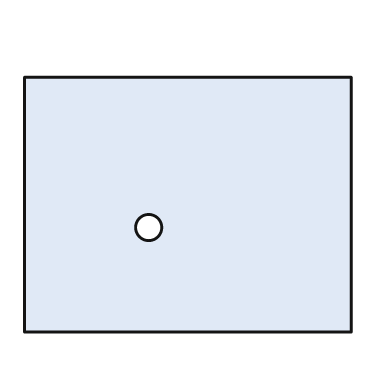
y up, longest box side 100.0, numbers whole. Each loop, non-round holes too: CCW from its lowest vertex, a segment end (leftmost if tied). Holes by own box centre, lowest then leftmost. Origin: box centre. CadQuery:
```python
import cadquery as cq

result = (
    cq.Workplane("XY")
    .moveTo(-50.0, -39.0)
    .lineTo(50.0, -39.0)
    .lineTo(50.0, 39.0)
    .lineTo(-50.0, 39.0)
    .close()
    .moveTo(-12.0, -7.0)
    .circle(4.0)
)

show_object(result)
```